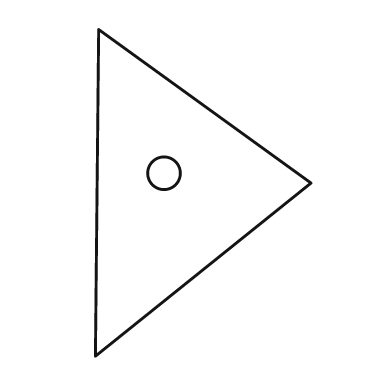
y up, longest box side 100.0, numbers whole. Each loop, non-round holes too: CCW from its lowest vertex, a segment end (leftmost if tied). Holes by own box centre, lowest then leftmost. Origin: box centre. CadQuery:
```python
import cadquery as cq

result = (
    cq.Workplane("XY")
    .moveTo(-33.0, -50.0)
    .lineTo(33.0, 3.0)
    .lineTo(-32.0, 50.0)
    .close()
    .moveTo(-12.0, 6.0)
    .circle(5.0)
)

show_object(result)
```